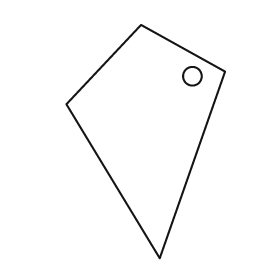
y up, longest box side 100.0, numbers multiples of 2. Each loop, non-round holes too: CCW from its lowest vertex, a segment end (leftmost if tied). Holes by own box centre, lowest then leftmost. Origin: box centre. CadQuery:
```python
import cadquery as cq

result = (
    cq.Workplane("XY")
    .moveTo(6.0, -50.0)
    .lineTo(34.0, 30.0)
    .lineTo(-2.0, 50.0)
    .lineTo(-34.0, 16.0)
    .close()
    .moveTo(20.0, 28.0)
    .circle(4.0)
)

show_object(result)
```